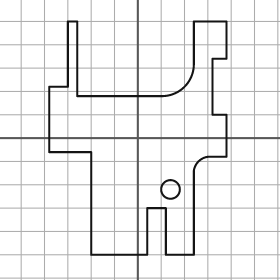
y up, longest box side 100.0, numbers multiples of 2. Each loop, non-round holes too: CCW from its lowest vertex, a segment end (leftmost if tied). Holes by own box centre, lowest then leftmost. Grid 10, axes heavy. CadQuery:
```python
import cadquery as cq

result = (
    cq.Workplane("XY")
    .moveTo(-20.0, -50.0)
    .lineTo(4.0, -50.0)
    .lineTo(4.0, -30.0)
    .lineTo(12.0, -30.0)
    .lineTo(12.0, -50.0)
    .lineTo(24.0, -50.0)
    .lineTo(24.0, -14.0)
    .threePointArc((26.0, -10.0), (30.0, -8.0))
    .lineTo(38.0, -8.0)
    .lineTo(38.0, 10.0)
    .lineTo(32.0, 10.0)
    .lineTo(32.0, 34.0)
    .lineTo(38.0, 34.0)
    .lineTo(38.0, 50.0)
    .lineTo(24.0, 50.0)
    .lineTo(24.0, 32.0)
    .threePointArc((20.0, 22.0), (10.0, 18.0))
    .lineTo(-26.0, 18.0)
    .lineTo(-26.0, 50.0)
    .lineTo(-30.0, 50.0)
    .lineTo(-30.0, 22.0)
    .lineTo(-38.0, 22.0)
    .lineTo(-38.0, -6.0)
    .lineTo(-20.0, -6.0)
    .close()
    .moveTo(14.0, -22.0)
    .circle(4.0)
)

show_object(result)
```